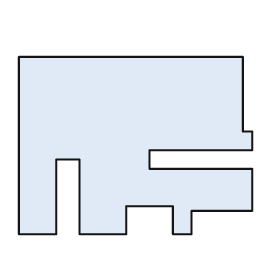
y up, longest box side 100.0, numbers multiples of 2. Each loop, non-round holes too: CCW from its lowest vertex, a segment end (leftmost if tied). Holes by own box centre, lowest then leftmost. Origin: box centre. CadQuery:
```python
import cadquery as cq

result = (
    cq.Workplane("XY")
    .moveTo(-50.0, -38.0)
    .lineTo(-34.0, -38.0)
    .lineTo(-34.0, -6.0)
    .lineTo(-24.0, -6.0)
    .lineTo(-24.0, -38.0)
    .lineTo(-4.0, -38.0)
    .lineTo(-4.0, -26.0)
    .lineTo(16.0, -26.0)
    .lineTo(16.0, -38.0)
    .lineTo(24.0, -38.0)
    .lineTo(24.0, -28.0)
    .lineTo(50.0, -28.0)
    .lineTo(50.0, -10.0)
    .lineTo(6.0, -10.0)
    .lineTo(6.0, -2.0)
    .lineTo(50.0, -2.0)
    .lineTo(50.0, 6.0)
    .lineTo(46.0, 6.0)
    .lineTo(46.0, 38.0)
    .lineTo(-50.0, 38.0)
    .close()
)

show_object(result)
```